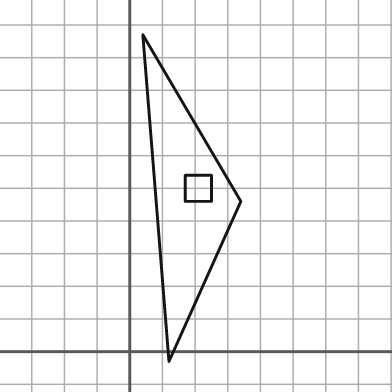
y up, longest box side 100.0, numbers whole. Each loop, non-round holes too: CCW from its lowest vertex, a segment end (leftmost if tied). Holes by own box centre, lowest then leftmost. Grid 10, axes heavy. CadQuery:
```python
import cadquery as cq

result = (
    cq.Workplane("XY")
    .moveTo(12.0, -3.0)
    .lineTo(34.0, 46.0)
    .lineTo(4.0, 97.0)
    .close()
    .moveTo(17.0, 46.0)
    .lineTo(25.0, 46.0)
    .lineTo(25.0, 54.0)
    .lineTo(17.0, 54.0)
    .close()
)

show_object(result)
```